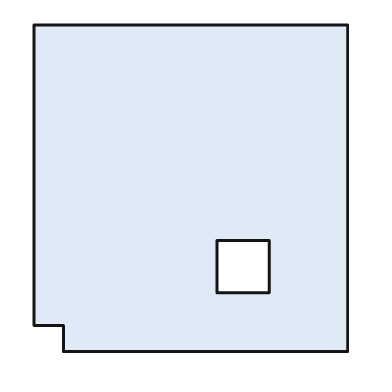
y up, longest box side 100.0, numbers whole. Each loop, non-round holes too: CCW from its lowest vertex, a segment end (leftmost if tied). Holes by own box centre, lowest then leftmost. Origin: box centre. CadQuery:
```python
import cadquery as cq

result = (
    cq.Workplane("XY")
    .moveTo(-39.0, -50.0)
    .lineTo(48.0, -50.0)
    .lineTo(48.0, 50.0)
    .lineTo(-48.0, 50.0)
    .lineTo(-48.0, -42.0)
    .lineTo(-39.0, -42.0)
    .close()
    .moveTo(8.0, -32.0)
    .lineTo(24.0, -32.0)
    .lineTo(24.0, -16.0)
    .lineTo(8.0, -16.0)
    .close()
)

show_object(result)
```